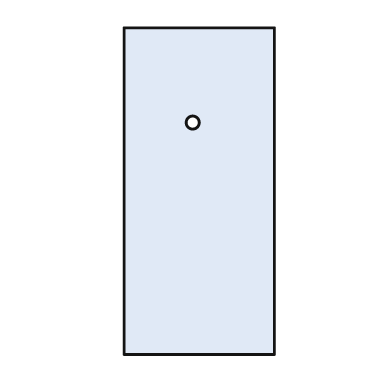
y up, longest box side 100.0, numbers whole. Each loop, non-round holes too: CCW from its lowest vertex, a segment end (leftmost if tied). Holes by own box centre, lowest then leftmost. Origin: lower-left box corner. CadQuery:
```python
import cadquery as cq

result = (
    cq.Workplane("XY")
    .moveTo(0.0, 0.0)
    .lineTo(46.0, 0.0)
    .lineTo(46.0, 100.0)
    .lineTo(0.0, 100.0)
    .close()
    .moveTo(21.0, 71.0)
    .circle(2.0)
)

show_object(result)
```